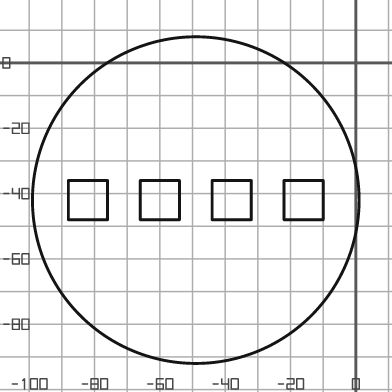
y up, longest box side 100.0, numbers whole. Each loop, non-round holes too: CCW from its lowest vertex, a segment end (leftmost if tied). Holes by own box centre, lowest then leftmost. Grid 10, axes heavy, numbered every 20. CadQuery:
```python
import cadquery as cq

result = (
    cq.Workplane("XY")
    .moveTo(-49.0, -42.0)
    .circle(50.0)
    .moveTo(-88.0, -48.0)
    .lineTo(-76.0, -48.0)
    .lineTo(-76.0, -36.0)
    .lineTo(-88.0, -36.0)
    .close()
    .moveTo(-66.0, -48.0)
    .lineTo(-54.0, -48.0)
    .lineTo(-54.0, -36.0)
    .lineTo(-66.0, -36.0)
    .close()
    .moveTo(-44.0, -48.0)
    .lineTo(-32.0, -48.0)
    .lineTo(-32.0, -36.0)
    .lineTo(-44.0, -36.0)
    .close()
    .moveTo(-22.0, -48.0)
    .lineTo(-10.0, -48.0)
    .lineTo(-10.0, -36.0)
    .lineTo(-22.0, -36.0)
    .close()
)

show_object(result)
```